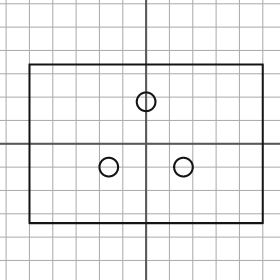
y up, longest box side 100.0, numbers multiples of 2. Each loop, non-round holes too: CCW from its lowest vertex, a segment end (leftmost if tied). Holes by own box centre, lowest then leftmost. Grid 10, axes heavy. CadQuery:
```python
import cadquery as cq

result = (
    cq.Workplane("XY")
    .moveTo(-50.0, -34.0)
    .lineTo(50.0, -34.0)
    .lineTo(50.0, 34.0)
    .lineTo(-50.0, 34.0)
    .close()
    .moveTo(-16.0, -10.0)
    .circle(4.0)
    .moveTo(16.0, -10.0)
    .circle(4.0)
    .moveTo(0.0, 18.0)
    .circle(4.0)
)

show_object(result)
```